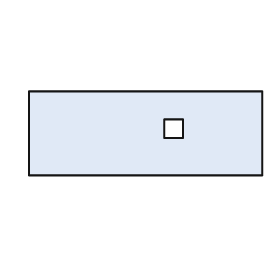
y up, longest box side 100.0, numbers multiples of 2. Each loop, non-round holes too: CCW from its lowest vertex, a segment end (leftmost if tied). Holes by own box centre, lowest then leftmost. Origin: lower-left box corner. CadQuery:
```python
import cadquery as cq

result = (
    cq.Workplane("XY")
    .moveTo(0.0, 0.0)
    .lineTo(100.0, 0.0)
    .lineTo(100.0, 36.0)
    .lineTo(0.0, 36.0)
    .close()
    .moveTo(58.0, 16.0)
    .lineTo(66.0, 16.0)
    .lineTo(66.0, 24.0)
    .lineTo(58.0, 24.0)
    .close()
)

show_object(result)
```